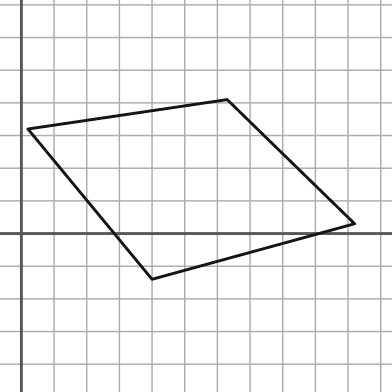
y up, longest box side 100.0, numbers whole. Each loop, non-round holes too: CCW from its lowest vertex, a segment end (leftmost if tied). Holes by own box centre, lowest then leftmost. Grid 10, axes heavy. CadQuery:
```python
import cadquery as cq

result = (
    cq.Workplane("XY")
    .moveTo(40.0, -14.0)
    .lineTo(102.0, 3.0)
    .lineTo(63.0, 41.0)
    .lineTo(2.0, 32.0)
    .close()
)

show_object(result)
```